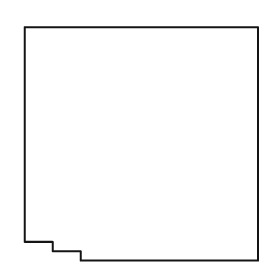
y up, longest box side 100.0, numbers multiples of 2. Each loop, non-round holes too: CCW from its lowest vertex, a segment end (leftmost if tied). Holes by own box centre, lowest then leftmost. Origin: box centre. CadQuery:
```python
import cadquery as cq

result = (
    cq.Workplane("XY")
    .moveTo(-26.0, -50.0)
    .lineTo(50.0, -50.0)
    .lineTo(50.0, 50.0)
    .lineTo(-50.0, 50.0)
    .lineTo(-50.0, -42.0)
    .lineTo(-38.0, -42.0)
    .lineTo(-38.0, -46.0)
    .lineTo(-26.0, -46.0)
    .close()
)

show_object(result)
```